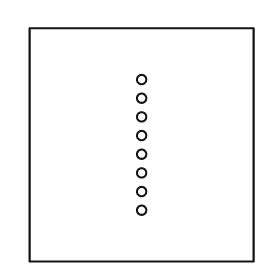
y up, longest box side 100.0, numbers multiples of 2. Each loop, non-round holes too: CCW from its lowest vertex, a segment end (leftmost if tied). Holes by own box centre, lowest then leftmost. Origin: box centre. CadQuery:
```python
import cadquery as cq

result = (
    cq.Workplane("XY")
    .moveTo(-48.0, -50.0)
    .lineTo(48.0, -50.0)
    .lineTo(48.0, 50.0)
    .lineTo(-48.0, 50.0)
    .close()
    .moveTo(0.0, -28.0)
    .circle(2.0)
    .moveTo(0.0, -20.0)
    .circle(2.0)
    .moveTo(0.0, -12.0)
    .circle(2.0)
    .moveTo(0.0, -4.0)
    .circle(2.0)
    .moveTo(0.0, 4.0)
    .circle(2.0)
    .moveTo(0.0, 12.0)
    .circle(2.0)
    .moveTo(0.0, 20.0)
    .circle(2.0)
    .moveTo(0.0, 28.0)
    .circle(2.0)
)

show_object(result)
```